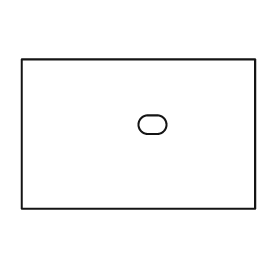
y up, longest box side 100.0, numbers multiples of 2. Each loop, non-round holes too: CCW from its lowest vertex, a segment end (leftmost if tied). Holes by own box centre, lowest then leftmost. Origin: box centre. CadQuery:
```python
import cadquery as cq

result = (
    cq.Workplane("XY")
    .moveTo(-50.0, -32.0)
    .lineTo(50.0, -32.0)
    .lineTo(50.0, 32.0)
    .lineTo(-50.0, 32.0)
    .close()
    .moveTo(4.0, 0.0)
    .lineTo(8.0, 0.0)
    .threePointArc((12.0, 4.0), (8.0, 8.0))
    .lineTo(4.0, 8.0)
    .threePointArc((0.0, 4.0), (4.0, 0.0))
    .close()
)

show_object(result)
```